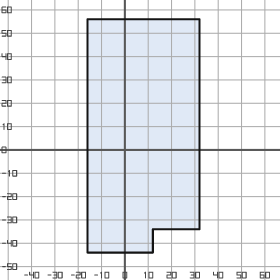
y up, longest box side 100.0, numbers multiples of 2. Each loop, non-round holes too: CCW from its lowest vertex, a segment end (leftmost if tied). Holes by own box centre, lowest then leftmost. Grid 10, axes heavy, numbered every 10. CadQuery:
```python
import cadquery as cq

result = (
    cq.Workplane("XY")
    .moveTo(-16.0, -44.0)
    .lineTo(12.0, -44.0)
    .lineTo(12.0, -34.0)
    .lineTo(32.0, -34.0)
    .lineTo(32.0, 56.0)
    .lineTo(-16.0, 56.0)
    .close()
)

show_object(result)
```